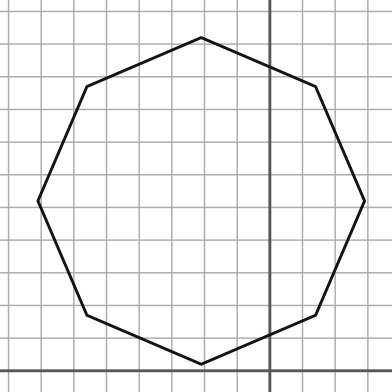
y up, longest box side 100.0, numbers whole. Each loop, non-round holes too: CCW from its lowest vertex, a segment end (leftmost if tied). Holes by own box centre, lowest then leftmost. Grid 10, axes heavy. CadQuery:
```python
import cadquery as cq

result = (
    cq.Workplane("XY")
    .moveTo(-21.0, 2.0)
    .lineTo(14.0, 17.0)
    .lineTo(29.0, 52.0)
    .lineTo(14.0, 87.0)
    .lineTo(-21.0, 102.0)
    .lineTo(-56.0, 87.0)
    .lineTo(-71.0, 52.0)
    .lineTo(-56.0, 17.0)
    .close()
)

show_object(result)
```